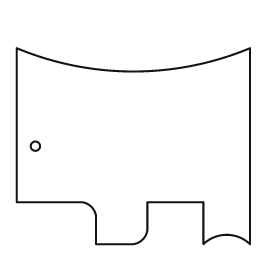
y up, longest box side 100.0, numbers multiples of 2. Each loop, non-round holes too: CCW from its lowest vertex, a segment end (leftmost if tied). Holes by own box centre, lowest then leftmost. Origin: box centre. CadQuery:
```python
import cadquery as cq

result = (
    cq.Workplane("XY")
    .moveTo(-16.0, -42.0)
    .lineTo(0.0, -42.0)
    .threePointArc((4.0, -40.0), (6.0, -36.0))
    .lineTo(6.0, -24.0)
    .lineTo(30.0, -24.0)
    .lineTo(30.0, -42.0)
    .threePointArc((40.0, -38.0), (50.0, -42.0))
    .lineTo(50.0, 42.0)
    .threePointArc((0.0, 32.0), (-50.0, 42.0))
    .lineTo(-50.0, -24.0)
    .lineTo(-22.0, -24.0)
    .threePointArc((-18.0, -26.0), (-16.0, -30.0))
    .close()
    .moveTo(-42.0, 0.0)
    .circle(2.0)
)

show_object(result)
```